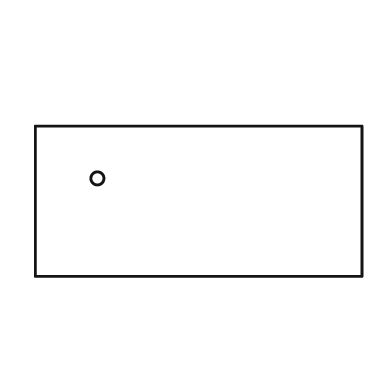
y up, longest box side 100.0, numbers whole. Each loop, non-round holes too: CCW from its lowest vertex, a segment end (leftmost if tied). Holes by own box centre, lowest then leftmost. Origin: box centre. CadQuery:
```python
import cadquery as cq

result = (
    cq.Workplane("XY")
    .moveTo(-50.0, -23.0)
    .lineTo(50.0, -23.0)
    .lineTo(50.0, 23.0)
    .lineTo(-50.0, 23.0)
    .close()
    .moveTo(-31.0, 7.0)
    .circle(2.0)
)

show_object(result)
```